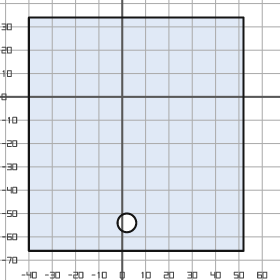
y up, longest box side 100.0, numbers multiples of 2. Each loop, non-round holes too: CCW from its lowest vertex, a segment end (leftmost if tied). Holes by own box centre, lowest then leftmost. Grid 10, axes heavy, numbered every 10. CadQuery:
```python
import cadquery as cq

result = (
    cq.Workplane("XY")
    .moveTo(-40.0, -66.0)
    .lineTo(52.0, -66.0)
    .lineTo(52.0, 34.0)
    .lineTo(-40.0, 34.0)
    .close()
    .moveTo(2.0, -54.0)
    .circle(4.0)
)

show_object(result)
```